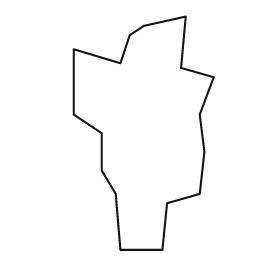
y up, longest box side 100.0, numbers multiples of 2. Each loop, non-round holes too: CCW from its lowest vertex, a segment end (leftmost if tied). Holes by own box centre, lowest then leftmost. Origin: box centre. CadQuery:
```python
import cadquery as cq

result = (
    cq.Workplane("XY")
    .moveTo(-10.0, -50.0)
    .lineTo(8.0, -50.0)
    .lineTo(10.0, -30.0)
    .lineTo(24.0, -26.0)
    .lineTo(26.0, -8.0)
    .lineTo(24.0, 8.0)
    .lineTo(30.0, 24.0)
    .lineTo(16.0, 28.0)
    .lineTo(18.0, 50.0)
    .lineTo(0.0, 46.0)
    .lineTo(-6.0, 42.0)
    .lineTo(-10.0, 30.0)
    .lineTo(-30.0, 36.0)
    .lineTo(-30.0, 8.0)
    .lineTo(-18.0, 0.0)
    .lineTo(-18.0, -16.0)
    .lineTo(-12.0, -26.0)
    .close()
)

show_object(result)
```